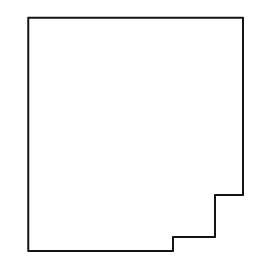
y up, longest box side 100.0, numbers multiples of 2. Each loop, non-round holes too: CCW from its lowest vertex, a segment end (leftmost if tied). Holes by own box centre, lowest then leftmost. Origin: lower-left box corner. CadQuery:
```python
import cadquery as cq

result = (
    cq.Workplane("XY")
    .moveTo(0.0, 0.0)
    .lineTo(62.0, 0.0)
    .lineTo(62.0, 6.0)
    .lineTo(80.0, 6.0)
    .lineTo(80.0, 24.0)
    .lineTo(92.0, 24.0)
    .lineTo(92.0, 100.0)
    .lineTo(0.0, 100.0)
    .close()
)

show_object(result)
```